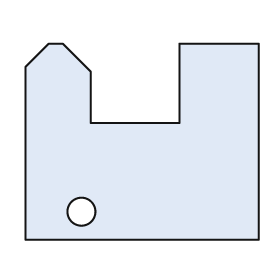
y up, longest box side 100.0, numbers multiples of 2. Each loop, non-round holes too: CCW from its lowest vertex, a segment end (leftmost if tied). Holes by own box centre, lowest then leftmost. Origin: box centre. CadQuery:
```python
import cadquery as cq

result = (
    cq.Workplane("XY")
    .moveTo(-50.0, -42.0)
    .lineTo(50.0, -42.0)
    .lineTo(50.0, 42.0)
    .lineTo(16.0, 42.0)
    .lineTo(16.0, 8.0)
    .lineTo(-22.0, 8.0)
    .lineTo(-22.0, 30.0)
    .lineTo(-34.0, 42.0)
    .lineTo(-40.0, 42.0)
    .lineTo(-50.0, 32.0)
    .close()
    .moveTo(-26.0, -30.0)
    .circle(6.0)
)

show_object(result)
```